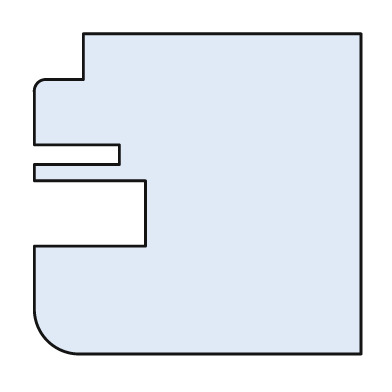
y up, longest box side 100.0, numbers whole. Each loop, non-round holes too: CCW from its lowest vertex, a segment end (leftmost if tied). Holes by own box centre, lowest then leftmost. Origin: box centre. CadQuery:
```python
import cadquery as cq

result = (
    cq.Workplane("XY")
    .moveTo(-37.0, -49.0)
    .lineTo(50.0, -49.0)
    .lineTo(50.0, 49.0)
    .lineTo(-35.0, 49.0)
    .lineTo(-35.0, 35.0)
    .lineTo(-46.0, 35.0)
    .threePointArc((-49.0, 34.0), (-50.0, 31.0))
    .lineTo(-50.0, 15.0)
    .lineTo(-24.0, 15.0)
    .lineTo(-24.0, 9.0)
    .lineTo(-50.0, 9.0)
    .lineTo(-50.0, 4.0)
    .lineTo(-16.0, 4.0)
    .lineTo(-16.0, -16.0)
    .lineTo(-50.0, -16.0)
    .lineTo(-50.0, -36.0)
    .threePointArc((-46.0, -45.0), (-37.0, -49.0))
    .close()
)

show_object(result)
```